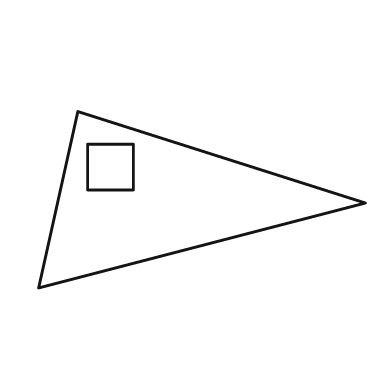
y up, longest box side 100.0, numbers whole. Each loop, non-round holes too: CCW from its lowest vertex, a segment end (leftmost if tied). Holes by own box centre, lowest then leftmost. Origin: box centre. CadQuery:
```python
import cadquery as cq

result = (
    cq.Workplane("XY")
    .moveTo(-50.0, -27.0)
    .lineTo(50.0, -1.0)
    .lineTo(-38.0, 27.0)
    .close()
    .moveTo(-35.0, 3.0)
    .lineTo(-21.0, 3.0)
    .lineTo(-21.0, 17.0)
    .lineTo(-35.0, 17.0)
    .close()
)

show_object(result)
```